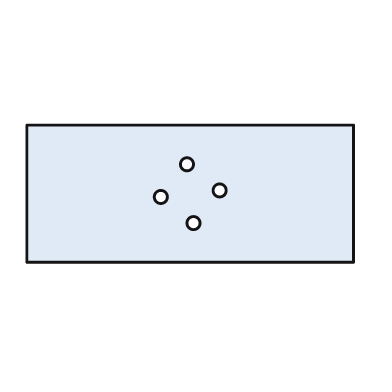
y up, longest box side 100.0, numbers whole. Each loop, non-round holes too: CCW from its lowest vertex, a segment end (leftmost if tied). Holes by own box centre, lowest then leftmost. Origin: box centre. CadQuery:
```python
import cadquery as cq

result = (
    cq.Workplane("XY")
    .moveTo(-50.0, -21.0)
    .lineTo(50.0, -21.0)
    .lineTo(50.0, 21.0)
    .lineTo(-50.0, 21.0)
    .close()
    .moveTo(1.0, -9.0)
    .circle(2.0)
    .moveTo(-9.0, -1.0)
    .circle(2.0)
    .moveTo(9.0, 1.0)
    .circle(2.0)
    .moveTo(-1.0, 9.0)
    .circle(2.0)
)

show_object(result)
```